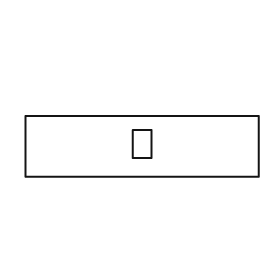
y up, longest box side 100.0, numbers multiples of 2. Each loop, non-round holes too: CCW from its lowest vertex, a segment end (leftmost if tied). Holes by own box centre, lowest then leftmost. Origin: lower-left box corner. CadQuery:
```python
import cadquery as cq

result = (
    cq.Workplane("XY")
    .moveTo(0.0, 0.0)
    .lineTo(100.0, 0.0)
    .lineTo(100.0, 26.0)
    .lineTo(0.0, 26.0)
    .close()
    .moveTo(46.0, 8.0)
    .lineTo(54.0, 8.0)
    .lineTo(54.0, 20.0)
    .lineTo(46.0, 20.0)
    .close()
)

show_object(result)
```